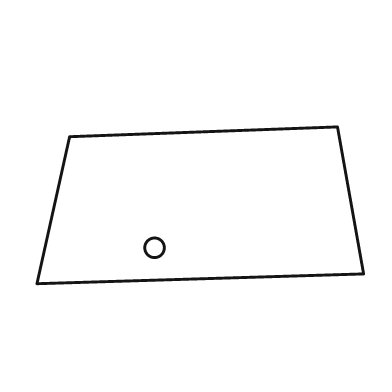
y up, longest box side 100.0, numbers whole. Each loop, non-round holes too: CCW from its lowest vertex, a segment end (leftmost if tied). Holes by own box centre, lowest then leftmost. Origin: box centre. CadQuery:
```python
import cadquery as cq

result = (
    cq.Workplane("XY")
    .moveTo(-50.0, -24.0)
    .lineTo(50.0, -21.0)
    .lineTo(42.0, 24.0)
    .lineTo(-40.0, 21.0)
    .close()
    .moveTo(-14.0, -13.0)
    .circle(3.0)
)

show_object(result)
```